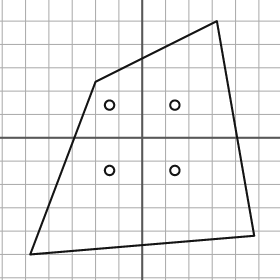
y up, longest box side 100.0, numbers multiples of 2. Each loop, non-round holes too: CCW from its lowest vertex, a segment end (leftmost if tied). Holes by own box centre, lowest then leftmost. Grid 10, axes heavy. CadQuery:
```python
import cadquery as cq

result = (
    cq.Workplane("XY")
    .moveTo(-48.0, -50.0)
    .lineTo(48.0, -42.0)
    .lineTo(32.0, 50.0)
    .lineTo(-20.0, 24.0)
    .close()
    .moveTo(-14.0, -14.0)
    .circle(2.0)
    .moveTo(14.0, -14.0)
    .circle(2.0)
    .moveTo(-14.0, 14.0)
    .circle(2.0)
    .moveTo(14.0, 14.0)
    .circle(2.0)
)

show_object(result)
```